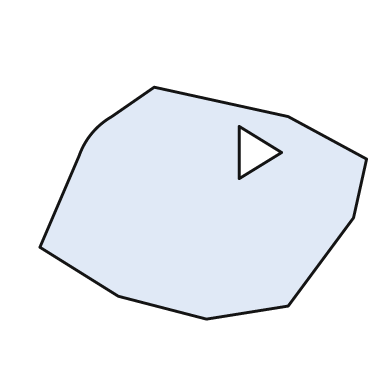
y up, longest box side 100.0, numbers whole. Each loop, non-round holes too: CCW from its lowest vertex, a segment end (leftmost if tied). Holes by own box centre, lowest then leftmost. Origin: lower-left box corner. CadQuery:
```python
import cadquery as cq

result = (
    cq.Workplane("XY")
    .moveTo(51.0, 0.0)
    .lineTo(76.0, 4.0)
    .lineTo(96.0, 31.0)
    .lineTo(100.0, 49.0)
    .lineTo(76.0, 62.0)
    .lineTo(35.0, 71.0)
    .lineTo(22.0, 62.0)
    .threePointArc((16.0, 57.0), (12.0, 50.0))
    .lineTo(0.0, 22.0)
    .lineTo(24.0, 7.0)
    .close()
    .moveTo(61.0, 43.0)
    .lineTo(74.0, 51.0)
    .lineTo(61.0, 59.0)
    .close()
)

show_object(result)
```